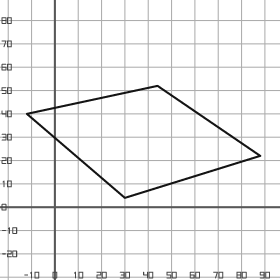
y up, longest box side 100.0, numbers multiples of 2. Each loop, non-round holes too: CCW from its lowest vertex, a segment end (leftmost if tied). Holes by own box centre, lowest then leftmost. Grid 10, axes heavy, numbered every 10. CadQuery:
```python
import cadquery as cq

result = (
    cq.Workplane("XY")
    .moveTo(30.0, 4.0)
    .lineTo(88.0, 22.0)
    .lineTo(44.0, 52.0)
    .lineTo(-12.0, 40.0)
    .close()
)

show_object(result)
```